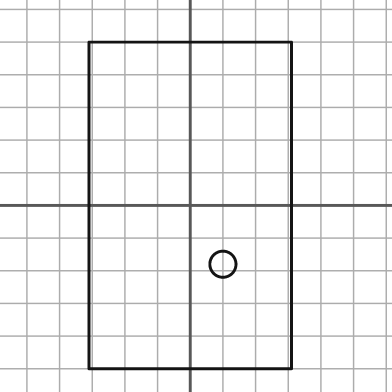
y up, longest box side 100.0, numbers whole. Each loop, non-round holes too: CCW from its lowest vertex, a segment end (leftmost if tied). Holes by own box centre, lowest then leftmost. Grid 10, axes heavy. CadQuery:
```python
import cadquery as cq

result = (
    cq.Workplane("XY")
    .moveTo(-31.0, -50.0)
    .lineTo(31.0, -50.0)
    .lineTo(31.0, 50.0)
    .lineTo(-31.0, 50.0)
    .close()
    .moveTo(10.0, -18.0)
    .circle(4.0)
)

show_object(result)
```